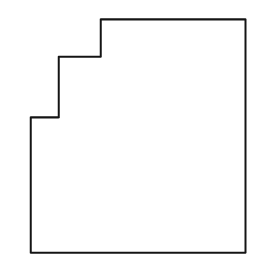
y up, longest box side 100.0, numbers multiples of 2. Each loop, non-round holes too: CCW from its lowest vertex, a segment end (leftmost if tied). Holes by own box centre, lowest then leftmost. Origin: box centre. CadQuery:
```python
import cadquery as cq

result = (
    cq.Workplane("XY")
    .moveTo(-46.0, -50.0)
    .lineTo(46.0, -50.0)
    .lineTo(46.0, 50.0)
    .lineTo(-16.0, 50.0)
    .lineTo(-16.0, 34.0)
    .lineTo(-34.0, 34.0)
    .lineTo(-34.0, 8.0)
    .lineTo(-46.0, 8.0)
    .close()
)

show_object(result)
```